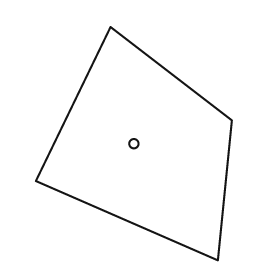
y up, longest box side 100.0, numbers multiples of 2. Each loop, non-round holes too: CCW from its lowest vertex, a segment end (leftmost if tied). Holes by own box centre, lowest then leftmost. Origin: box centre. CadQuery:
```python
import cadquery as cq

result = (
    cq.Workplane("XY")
    .moveTo(36.0, -50.0)
    .lineTo(42.0, 10.0)
    .lineTo(-10.0, 50.0)
    .lineTo(-42.0, -16.0)
    .close()
    .moveTo(0.0, 0.0)
    .circle(2.0)
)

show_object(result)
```